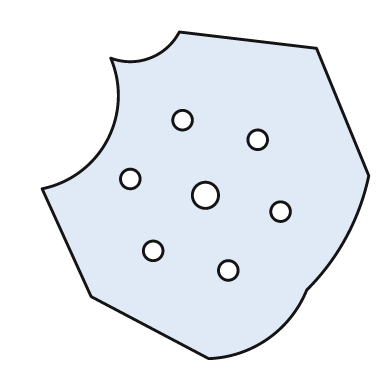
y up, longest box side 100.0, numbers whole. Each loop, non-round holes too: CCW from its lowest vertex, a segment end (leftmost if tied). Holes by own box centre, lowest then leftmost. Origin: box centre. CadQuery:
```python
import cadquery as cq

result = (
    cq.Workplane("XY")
    .moveTo(1.0, -50.0)
    .threePointArc((19.0, -44.0), (31.0, -29.0))
    .threePointArc((43.0, -13.0), (50.0, 6.0))
    .lineTo(34.0, 45.0)
    .lineTo(-8.0, 50.0)
    .threePointArc((-17.0, 42.0), (-29.0, 42.0))
    .threePointArc((-30.0, 17.0), (-50.0, 2.0))
    .lineTo(-35.0, -31.0)
    .close()
    .moveTo(7.0, -23.0)
    .circle(3.0)
    .moveTo(-16.0, -17.0)
    .circle(3.0)
    .moveTo(23.0, -5.0)
    .circle(3.0)
    .moveTo(0.0, 0.0)
    .circle(4.0)
    .moveTo(-23.0, 5.0)
    .circle(3.0)
    .moveTo(16.0, 17.0)
    .circle(3.0)
    .moveTo(-7.0, 23.0)
    .circle(3.0)
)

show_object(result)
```